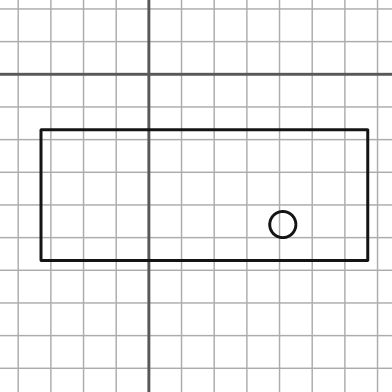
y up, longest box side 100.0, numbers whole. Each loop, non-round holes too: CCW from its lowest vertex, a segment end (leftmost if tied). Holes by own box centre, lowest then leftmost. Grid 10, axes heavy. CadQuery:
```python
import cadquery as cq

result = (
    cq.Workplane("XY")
    .moveTo(-33.0, -57.0)
    .lineTo(67.0, -57.0)
    .lineTo(67.0, -17.0)
    .lineTo(-33.0, -17.0)
    .close()
    .moveTo(41.0, -46.0)
    .circle(4.0)
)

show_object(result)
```